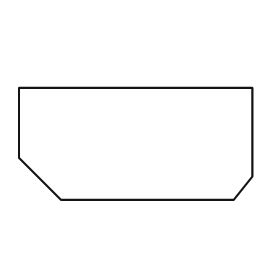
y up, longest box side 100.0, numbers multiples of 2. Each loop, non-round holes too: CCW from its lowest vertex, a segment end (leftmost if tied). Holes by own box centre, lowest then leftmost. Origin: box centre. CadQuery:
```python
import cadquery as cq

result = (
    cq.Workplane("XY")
    .moveTo(-32.0, -24.0)
    .lineTo(42.0, -24.0)
    .lineTo(50.0, -14.0)
    .lineTo(50.0, 24.0)
    .lineTo(-50.0, 24.0)
    .lineTo(-50.0, -6.0)
    .close()
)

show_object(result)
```